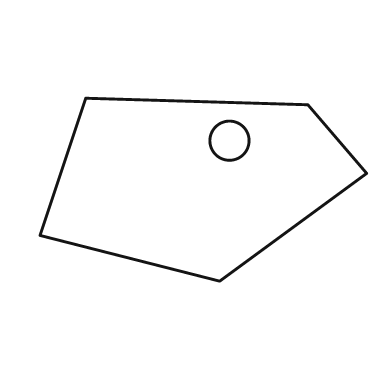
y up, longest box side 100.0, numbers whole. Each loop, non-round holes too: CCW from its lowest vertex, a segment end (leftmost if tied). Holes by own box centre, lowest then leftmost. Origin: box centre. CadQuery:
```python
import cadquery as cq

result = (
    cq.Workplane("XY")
    .moveTo(5.0, -28.0)
    .lineTo(50.0, 5.0)
    .lineTo(32.0, 26.0)
    .lineTo(-36.0, 28.0)
    .lineTo(-50.0, -14.0)
    .close()
    .moveTo(8.0, 15.0)
    .circle(6.0)
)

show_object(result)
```